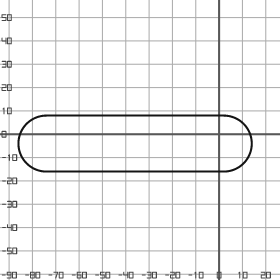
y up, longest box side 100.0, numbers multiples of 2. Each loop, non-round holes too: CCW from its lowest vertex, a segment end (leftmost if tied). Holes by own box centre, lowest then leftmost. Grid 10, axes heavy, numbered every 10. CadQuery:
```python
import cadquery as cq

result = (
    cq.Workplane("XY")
    .moveTo(-74.0, -16.0)
    .lineTo(2.0, -16.0)
    .threePointArc((14.0, -4.0), (2.0, 8.0))
    .lineTo(-74.0, 8.0)
    .threePointArc((-86.0, -4.0), (-74.0, -16.0))
    .close()
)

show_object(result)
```